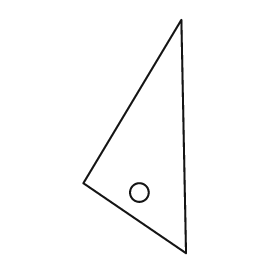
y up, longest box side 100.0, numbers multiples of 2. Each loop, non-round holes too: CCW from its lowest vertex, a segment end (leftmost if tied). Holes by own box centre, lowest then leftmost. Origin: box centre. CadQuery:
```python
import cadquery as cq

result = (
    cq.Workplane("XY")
    .moveTo(22.0, -50.0)
    .lineTo(20.0, 50.0)
    .lineTo(-22.0, -20.0)
    .close()
    .moveTo(2.0, -24.0)
    .circle(4.0)
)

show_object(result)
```